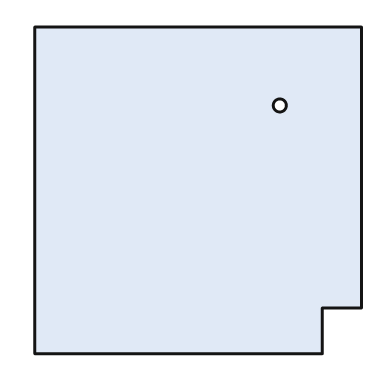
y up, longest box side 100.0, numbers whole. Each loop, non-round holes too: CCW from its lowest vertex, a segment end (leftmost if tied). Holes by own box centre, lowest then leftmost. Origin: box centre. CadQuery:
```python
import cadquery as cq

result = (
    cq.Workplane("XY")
    .moveTo(-50.0, -50.0)
    .lineTo(38.0, -50.0)
    .lineTo(38.0, -36.0)
    .lineTo(50.0, -36.0)
    .lineTo(50.0, 50.0)
    .lineTo(-50.0, 50.0)
    .close()
    .moveTo(25.0, 26.0)
    .circle(2.0)
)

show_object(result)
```